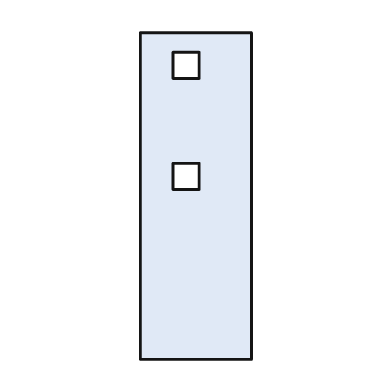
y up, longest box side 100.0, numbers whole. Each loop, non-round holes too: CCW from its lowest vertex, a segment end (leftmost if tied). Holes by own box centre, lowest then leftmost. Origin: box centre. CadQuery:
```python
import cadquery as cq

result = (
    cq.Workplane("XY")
    .moveTo(-17.0, -50.0)
    .lineTo(17.0, -50.0)
    .lineTo(17.0, 50.0)
    .lineTo(-17.0, 50.0)
    .close()
    .moveTo(-7.0, 2.0)
    .lineTo(1.0, 2.0)
    .lineTo(1.0, 10.0)
    .lineTo(-7.0, 10.0)
    .close()
    .moveTo(-7.0, 36.0)
    .lineTo(1.0, 36.0)
    .lineTo(1.0, 44.0)
    .lineTo(-7.0, 44.0)
    .close()
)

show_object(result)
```